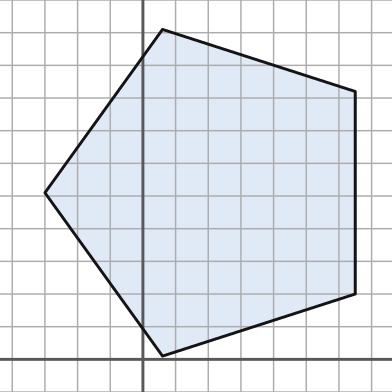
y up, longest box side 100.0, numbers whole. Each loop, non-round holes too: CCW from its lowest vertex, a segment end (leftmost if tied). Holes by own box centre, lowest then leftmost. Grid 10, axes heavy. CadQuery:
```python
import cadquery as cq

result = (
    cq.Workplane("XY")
    .moveTo(6.0, 1.0)
    .lineTo(65.0, 20.0)
    .lineTo(65.0, 82.0)
    .lineTo(6.0, 101.0)
    .lineTo(-30.0, 51.0)
    .close()
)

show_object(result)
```